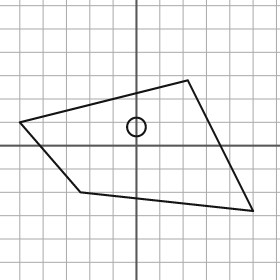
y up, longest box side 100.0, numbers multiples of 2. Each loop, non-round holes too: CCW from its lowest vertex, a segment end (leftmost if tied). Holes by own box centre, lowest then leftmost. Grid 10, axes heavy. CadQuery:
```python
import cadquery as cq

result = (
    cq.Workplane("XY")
    .moveTo(50.0, -28.0)
    .lineTo(22.0, 28.0)
    .lineTo(-50.0, 10.0)
    .lineTo(-24.0, -20.0)
    .close()
    .moveTo(0.0, 8.0)
    .circle(4.0)
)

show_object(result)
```